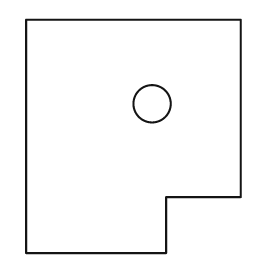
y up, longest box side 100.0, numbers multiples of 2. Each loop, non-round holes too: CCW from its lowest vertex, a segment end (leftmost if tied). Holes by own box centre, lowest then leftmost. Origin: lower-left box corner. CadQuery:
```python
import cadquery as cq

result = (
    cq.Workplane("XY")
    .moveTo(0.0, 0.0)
    .lineTo(60.0, 0.0)
    .lineTo(60.0, 24.0)
    .lineTo(92.0, 24.0)
    .lineTo(92.0, 100.0)
    .lineTo(0.0, 100.0)
    .close()
    .moveTo(54.0, 64.0)
    .circle(8.0)
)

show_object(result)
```